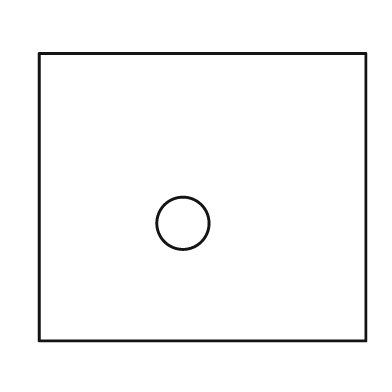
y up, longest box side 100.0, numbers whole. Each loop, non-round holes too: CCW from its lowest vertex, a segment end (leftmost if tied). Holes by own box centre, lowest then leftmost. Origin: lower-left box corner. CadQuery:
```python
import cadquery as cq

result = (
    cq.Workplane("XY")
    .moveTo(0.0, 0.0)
    .lineTo(100.0, 0.0)
    .lineTo(100.0, 88.0)
    .lineTo(0.0, 88.0)
    .close()
    .moveTo(44.0, 36.0)
    .circle(8.0)
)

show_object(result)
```